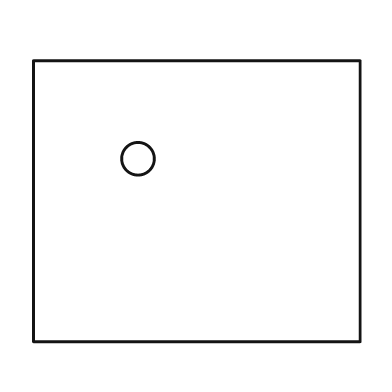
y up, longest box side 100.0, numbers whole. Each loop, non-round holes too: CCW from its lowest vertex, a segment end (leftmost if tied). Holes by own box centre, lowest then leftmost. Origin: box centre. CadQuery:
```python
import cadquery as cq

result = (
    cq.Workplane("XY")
    .moveTo(-50.0, -43.0)
    .lineTo(50.0, -43.0)
    .lineTo(50.0, 43.0)
    .lineTo(-50.0, 43.0)
    .close()
    .moveTo(-18.0, 13.0)
    .circle(5.0)
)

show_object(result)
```